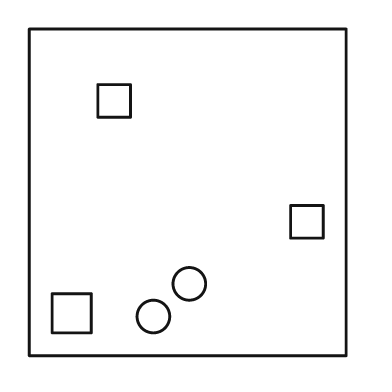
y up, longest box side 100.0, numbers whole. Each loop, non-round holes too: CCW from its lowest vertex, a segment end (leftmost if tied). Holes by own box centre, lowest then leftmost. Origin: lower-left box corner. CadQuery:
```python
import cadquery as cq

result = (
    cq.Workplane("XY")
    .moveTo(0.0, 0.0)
    .lineTo(97.0, 0.0)
    .lineTo(97.0, 100.0)
    .lineTo(0.0, 100.0)
    .close()
    .moveTo(38.0, 12.0)
    .circle(5.0)
    .moveTo(7.0, 7.0)
    .lineTo(19.0, 7.0)
    .lineTo(19.0, 19.0)
    .lineTo(7.0, 19.0)
    .close()
    .moveTo(49.0, 22.0)
    .circle(5.0)
    .moveTo(80.0, 36.0)
    .lineTo(90.0, 36.0)
    .lineTo(90.0, 46.0)
    .lineTo(80.0, 46.0)
    .close()
    .moveTo(21.0, 73.0)
    .lineTo(31.0, 73.0)
    .lineTo(31.0, 83.0)
    .lineTo(21.0, 83.0)
    .close()
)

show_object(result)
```